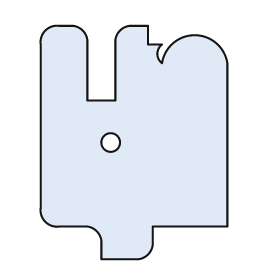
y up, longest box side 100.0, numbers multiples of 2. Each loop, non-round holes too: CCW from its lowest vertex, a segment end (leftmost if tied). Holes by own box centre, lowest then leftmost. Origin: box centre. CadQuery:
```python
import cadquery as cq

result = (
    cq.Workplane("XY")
    .moveTo(-14.0, -50.0)
    .lineTo(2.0, -50.0)
    .threePointArc((6.0, -48.0), (8.0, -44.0))
    .lineTo(8.0, -36.0)
    .lineTo(40.0, -36.0)
    .lineTo(40.0, 34.0)
    .threePointArc((26.0, 46.0), (12.0, 34.0))
    .threePointArc((10.0, 38.0), (12.0, 42.0))
    .lineTo(6.0, 42.0)
    .lineTo(6.0, 50.0)
    .lineTo(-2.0, 50.0)
    .threePointArc((-6.0, 48.0), (-8.0, 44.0))
    .lineTo(-8.0, 18.0)
    .lineTo(-20.0, 18.0)
    .lineTo(-20.0, 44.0)
    .threePointArc((-22.0, 48.0), (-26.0, 50.0))
    .lineTo(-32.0, 50.0)
    .threePointArc((-38.0, 48.0), (-40.0, 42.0))
    .lineTo(-40.0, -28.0)
    .threePointArc((-38.0, -34.0), (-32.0, -36.0))
    .lineTo(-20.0, -36.0)
    .threePointArc((-16.0, -38.0), (-14.0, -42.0))
    .close()
    .moveTo(-10.0, 0.0)
    .circle(4.0)
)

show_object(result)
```